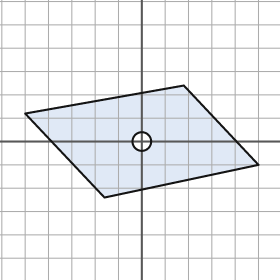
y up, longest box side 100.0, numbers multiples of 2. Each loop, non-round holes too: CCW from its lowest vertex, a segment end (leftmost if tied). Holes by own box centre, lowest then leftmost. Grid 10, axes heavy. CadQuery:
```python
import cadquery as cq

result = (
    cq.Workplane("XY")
    .moveTo(-16.0, -24.0)
    .lineTo(50.0, -10.0)
    .lineTo(18.0, 24.0)
    .lineTo(-50.0, 12.0)
    .close()
    .moveTo(0.0, 0.0)
    .circle(4.0)
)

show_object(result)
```